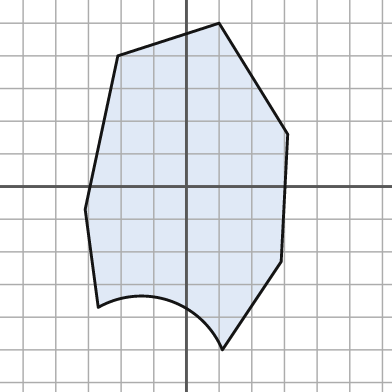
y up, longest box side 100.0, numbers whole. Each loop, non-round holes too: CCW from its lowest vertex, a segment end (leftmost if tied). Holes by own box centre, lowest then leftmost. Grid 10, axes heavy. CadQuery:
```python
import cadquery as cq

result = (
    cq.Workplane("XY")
    .moveTo(11.0, -50.0)
    .lineTo(29.0, -23.0)
    .lineTo(31.0, 16.0)
    .lineTo(10.0, 50.0)
    .lineTo(-21.0, 40.0)
    .lineTo(-31.0, -7.0)
    .lineTo(-27.0, -37.0)
    .threePointArc((-5.0, -35.0), (11.0, -50.0))
    .close()
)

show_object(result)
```